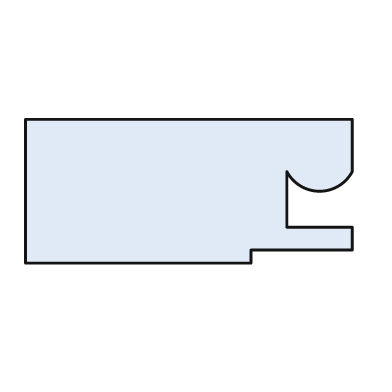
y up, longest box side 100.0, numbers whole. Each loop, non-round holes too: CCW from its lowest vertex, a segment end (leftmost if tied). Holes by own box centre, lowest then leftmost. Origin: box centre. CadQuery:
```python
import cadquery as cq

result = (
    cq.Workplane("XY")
    .moveTo(-50.0, -22.0)
    .lineTo(19.0, -22.0)
    .lineTo(19.0, -18.0)
    .lineTo(50.0, -18.0)
    .lineTo(50.0, -11.0)
    .lineTo(30.0, -11.0)
    .lineTo(30.0, 6.0)
    .threePointArc((40.0, 0.0), (50.0, 6.0))
    .lineTo(50.0, 22.0)
    .lineTo(-50.0, 22.0)
    .close()
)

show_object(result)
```